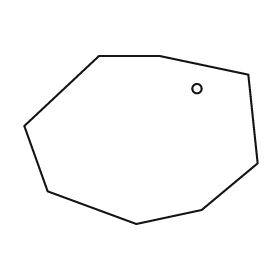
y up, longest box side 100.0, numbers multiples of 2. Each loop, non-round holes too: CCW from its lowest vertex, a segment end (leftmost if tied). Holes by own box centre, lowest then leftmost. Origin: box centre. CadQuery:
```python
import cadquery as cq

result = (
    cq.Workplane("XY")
    .moveTo(-2.0, -36.0)
    .lineTo(26.0, -30.0)
    .lineTo(50.0, -10.0)
    .lineTo(46.0, 28.0)
    .lineTo(8.0, 36.0)
    .lineTo(-18.0, 36.0)
    .lineTo(-50.0, 6.0)
    .lineTo(-40.0, -22.0)
    .close()
    .moveTo(24.0, 22.0)
    .circle(2.0)
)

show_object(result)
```